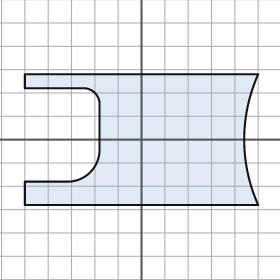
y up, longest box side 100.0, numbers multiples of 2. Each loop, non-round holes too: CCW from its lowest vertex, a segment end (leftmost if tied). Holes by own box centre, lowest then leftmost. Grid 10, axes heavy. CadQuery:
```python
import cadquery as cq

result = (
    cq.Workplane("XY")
    .moveTo(-50.0, -28.0)
    .lineTo(50.0, -28.0)
    .threePointArc((44.0, 0.0), (50.0, 28.0))
    .lineTo(-50.0, 28.0)
    .lineTo(-50.0, 22.0)
    .lineTo(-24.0, 22.0)
    .threePointArc((-20.0, 20.0), (-18.0, 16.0))
    .lineTo(-18.0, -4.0)
    .threePointArc((-22.0, -14.0), (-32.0, -18.0))
    .lineTo(-50.0, -18.0)
    .close()
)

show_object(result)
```